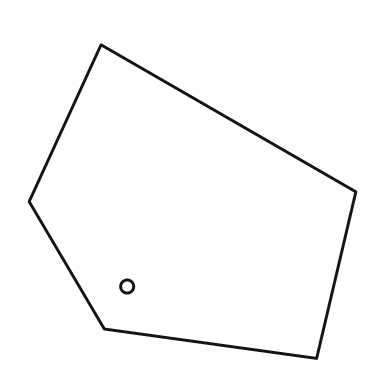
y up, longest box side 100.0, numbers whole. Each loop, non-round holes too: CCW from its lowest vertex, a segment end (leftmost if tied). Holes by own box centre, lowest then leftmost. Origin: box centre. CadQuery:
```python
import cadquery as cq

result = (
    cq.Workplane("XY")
    .moveTo(38.0, -48.0)
    .lineTo(50.0, 3.0)
    .lineTo(-28.0, 48.0)
    .lineTo(-50.0, 0.0)
    .lineTo(-27.0, -39.0)
    .close()
    .moveTo(-20.0, -26.0)
    .circle(2.0)
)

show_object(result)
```